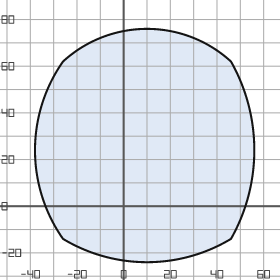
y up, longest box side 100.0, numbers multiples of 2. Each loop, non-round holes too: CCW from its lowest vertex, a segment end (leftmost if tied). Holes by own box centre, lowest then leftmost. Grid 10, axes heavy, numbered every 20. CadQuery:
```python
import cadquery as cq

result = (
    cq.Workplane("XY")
    .moveTo(-26.0, -14.0)
    .threePointArc((10.0, -24.0), (46.0, -14.0))
    .threePointArc((56.0, 24.0), (46.0, 62.0))
    .threePointArc((10.0, 76.0), (-26.0, 62.0))
    .threePointArc((-38.0, 24.0), (-26.0, -14.0))
    .close()
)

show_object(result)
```